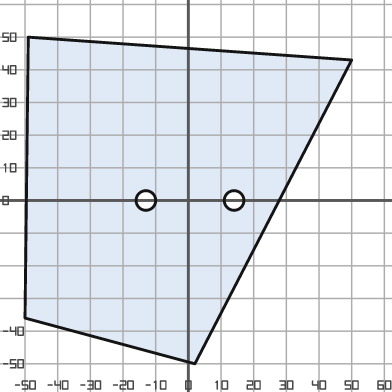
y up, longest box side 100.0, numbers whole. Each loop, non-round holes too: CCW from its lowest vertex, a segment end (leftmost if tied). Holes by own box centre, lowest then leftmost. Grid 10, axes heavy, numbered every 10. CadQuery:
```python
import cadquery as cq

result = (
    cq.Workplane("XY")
    .moveTo(2.0, -50.0)
    .lineTo(50.0, 43.0)
    .lineTo(-49.0, 50.0)
    .lineTo(-50.0, -36.0)
    .close()
    .moveTo(-13.0, 0.0)
    .circle(3.0)
    .moveTo(14.0, 0.0)
    .circle(3.0)
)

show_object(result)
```